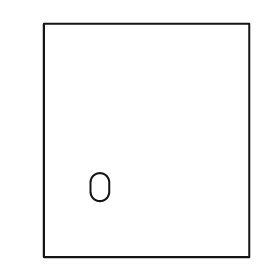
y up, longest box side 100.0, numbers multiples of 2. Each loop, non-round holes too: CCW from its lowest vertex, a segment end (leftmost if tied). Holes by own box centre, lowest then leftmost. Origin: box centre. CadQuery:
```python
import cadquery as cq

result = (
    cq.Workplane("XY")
    .moveTo(-44.0, -50.0)
    .lineTo(44.0, -50.0)
    .lineTo(44.0, 50.0)
    .lineTo(-44.0, 50.0)
    .close()
    .moveTo(-24.0, -22.0)
    .threePointArc((-20.0, -26.0), (-16.0, -22.0))
    .lineTo(-16.0, -18.0)
    .threePointArc((-20.0, -14.0), (-24.0, -18.0))
    .close()
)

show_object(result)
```